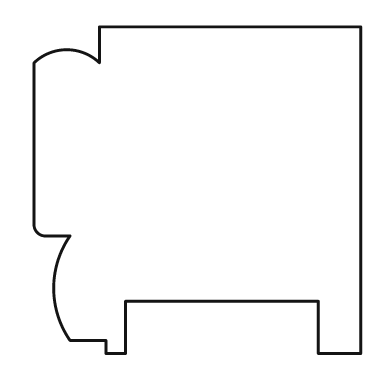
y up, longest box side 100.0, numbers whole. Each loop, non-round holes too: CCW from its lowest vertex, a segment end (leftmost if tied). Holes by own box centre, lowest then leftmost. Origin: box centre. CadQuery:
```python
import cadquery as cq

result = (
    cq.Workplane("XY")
    .moveTo(-28.0, -50.0)
    .lineTo(-22.0, -50.0)
    .lineTo(-22.0, -34.0)
    .lineTo(37.0, -34.0)
    .lineTo(37.0, -50.0)
    .lineTo(50.0, -50.0)
    .lineTo(50.0, 50.0)
    .lineTo(-30.0, 50.0)
    .lineTo(-30.0, 39.0)
    .threePointArc((-40.0, 43.0), (-50.0, 39.0))
    .lineTo(-50.0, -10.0)
    .threePointArc((-49.0, -13.0), (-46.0, -14.0))
    .lineTo(-39.0, -14.0)
    .threePointArc((-44.0, -30.0), (-39.0, -46.0))
    .lineTo(-28.0, -46.0)
    .close()
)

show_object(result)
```